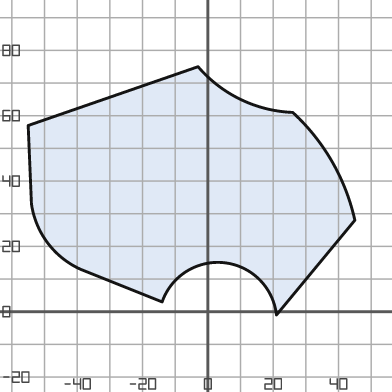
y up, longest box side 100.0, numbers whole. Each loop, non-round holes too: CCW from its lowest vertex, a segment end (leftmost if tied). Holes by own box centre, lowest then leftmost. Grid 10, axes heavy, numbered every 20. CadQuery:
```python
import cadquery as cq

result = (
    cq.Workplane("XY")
    .moveTo(21.0, -1.0)
    .lineTo(45.0, 28.0)
    .threePointArc((38.0, 46.0), (26.0, 61.0))
    .threePointArc((10.0, 65.0), (-3.0, 75.0))
    .lineTo(-55.0, 57.0)
    .lineTo(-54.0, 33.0)
    .threePointArc((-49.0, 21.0), (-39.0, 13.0))
    .lineTo(-14.0, 3.0)
    .threePointArc((5.0, 15.0), (21.0, -1.0))
    .close()
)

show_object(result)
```